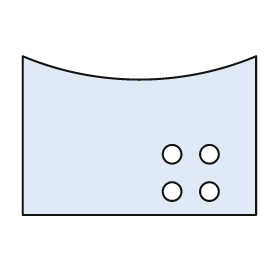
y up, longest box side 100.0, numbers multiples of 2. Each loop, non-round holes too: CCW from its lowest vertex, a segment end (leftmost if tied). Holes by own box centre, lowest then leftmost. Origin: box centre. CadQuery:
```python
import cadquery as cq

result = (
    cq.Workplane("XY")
    .moveTo(-50.0, -34.0)
    .lineTo(50.0, -34.0)
    .lineTo(50.0, 34.0)
    .threePointArc((0.0, 24.0), (-50.0, 34.0))
    .close()
    .moveTo(14.0, -24.0)
    .circle(4.0)
    .moveTo(30.0, -24.0)
    .circle(4.0)
    .moveTo(14.0, -8.0)
    .circle(4.0)
    .moveTo(30.0, -8.0)
    .circle(4.0)
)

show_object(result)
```